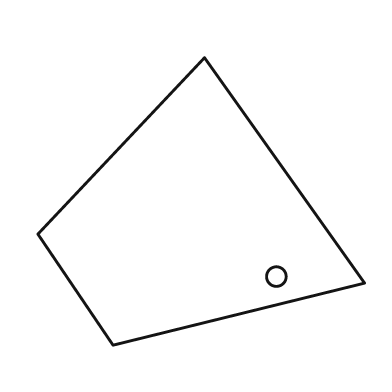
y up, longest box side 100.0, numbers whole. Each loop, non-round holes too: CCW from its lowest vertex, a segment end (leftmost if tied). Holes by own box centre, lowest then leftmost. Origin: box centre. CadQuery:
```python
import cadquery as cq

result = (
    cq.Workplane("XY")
    .moveTo(-27.0, -44.0)
    .lineTo(50.0, -25.0)
    .lineTo(1.0, 44.0)
    .lineTo(-50.0, -10.0)
    .close()
    .moveTo(23.0, -23.0)
    .circle(3.0)
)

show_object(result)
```